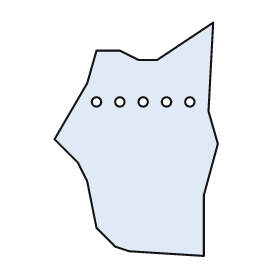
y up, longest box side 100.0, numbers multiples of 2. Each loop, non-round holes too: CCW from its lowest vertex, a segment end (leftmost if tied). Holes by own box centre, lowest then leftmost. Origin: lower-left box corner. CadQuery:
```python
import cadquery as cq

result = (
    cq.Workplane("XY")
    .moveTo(64.0, 0.0)
    .lineTo(64.0, 26.0)
    .lineTo(70.0, 48.0)
    .lineTo(66.0, 62.0)
    .lineTo(68.0, 100.0)
    .lineTo(44.0, 84.0)
    .lineTo(36.0, 84.0)
    .lineTo(28.0, 88.0)
    .lineTo(18.0, 88.0)
    .lineTo(14.0, 74.0)
    .lineTo(0.0, 50.0)
    .lineTo(10.0, 40.0)
    .lineTo(14.0, 32.0)
    .lineTo(18.0, 12.0)
    .lineTo(26.0, 4.0)
    .lineTo(32.0, 2.0)
    .close()
    .moveTo(18.0, 66.0)
    .circle(2.0)
    .moveTo(28.0, 66.0)
    .circle(2.0)
    .moveTo(38.0, 66.0)
    .circle(2.0)
    .moveTo(48.0, 66.0)
    .circle(2.0)
    .moveTo(58.0, 66.0)
    .circle(2.0)
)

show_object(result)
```